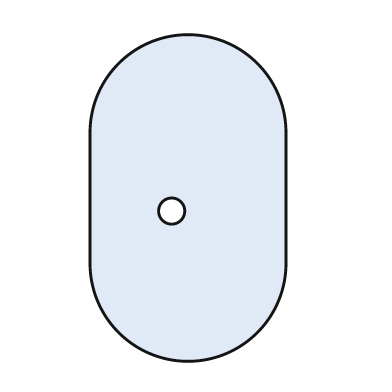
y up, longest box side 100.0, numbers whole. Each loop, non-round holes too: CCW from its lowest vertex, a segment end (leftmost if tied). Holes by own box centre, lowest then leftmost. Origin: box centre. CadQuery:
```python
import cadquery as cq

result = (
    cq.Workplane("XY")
    .moveTo(-30.0, -20.0)
    .threePointArc((0.0, -50.0), (30.0, -20.0))
    .lineTo(30.0, 20.0)
    .threePointArc((0.0, 50.0), (-30.0, 20.0))
    .close()
    .moveTo(-5.0, -4.0)
    .circle(4.0)
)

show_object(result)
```